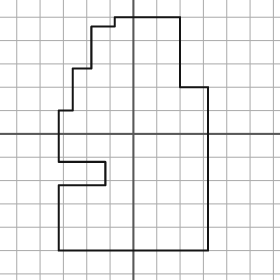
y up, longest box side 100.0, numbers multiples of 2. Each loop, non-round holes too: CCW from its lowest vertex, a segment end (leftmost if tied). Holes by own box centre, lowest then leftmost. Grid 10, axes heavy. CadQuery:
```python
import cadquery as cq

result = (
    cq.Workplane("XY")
    .moveTo(-32.0, -50.0)
    .lineTo(32.0, -50.0)
    .lineTo(32.0, 20.0)
    .lineTo(20.0, 20.0)
    .lineTo(20.0, 50.0)
    .lineTo(-8.0, 50.0)
    .lineTo(-8.0, 46.0)
    .lineTo(-18.0, 46.0)
    .lineTo(-18.0, 28.0)
    .lineTo(-26.0, 28.0)
    .lineTo(-26.0, 10.0)
    .lineTo(-32.0, 10.0)
    .lineTo(-32.0, -12.0)
    .lineTo(-12.0, -12.0)
    .lineTo(-12.0, -22.0)
    .lineTo(-32.0, -22.0)
    .close()
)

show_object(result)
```